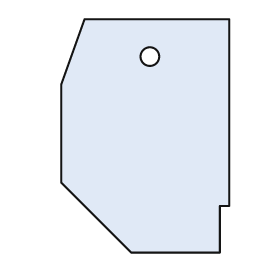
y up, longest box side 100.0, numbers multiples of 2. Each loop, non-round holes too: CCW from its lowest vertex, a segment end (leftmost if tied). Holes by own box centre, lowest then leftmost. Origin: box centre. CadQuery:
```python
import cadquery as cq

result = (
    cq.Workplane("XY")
    .moveTo(-6.0, -50.0)
    .lineTo(32.0, -50.0)
    .lineTo(32.0, -30.0)
    .lineTo(36.0, -30.0)
    .lineTo(36.0, 50.0)
    .lineTo(-26.0, 50.0)
    .lineTo(-36.0, 22.0)
    .lineTo(-36.0, -20.0)
    .close()
    .moveTo(2.0, 34.0)
    .circle(4.0)
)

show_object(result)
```